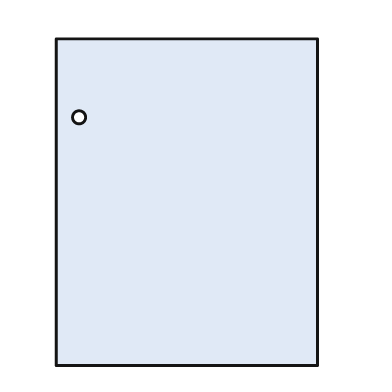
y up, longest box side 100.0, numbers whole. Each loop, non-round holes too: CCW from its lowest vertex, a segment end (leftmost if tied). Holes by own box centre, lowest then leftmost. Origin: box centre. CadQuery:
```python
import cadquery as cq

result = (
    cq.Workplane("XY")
    .moveTo(-40.0, -50.0)
    .lineTo(40.0, -50.0)
    .lineTo(40.0, 50.0)
    .lineTo(-40.0, 50.0)
    .close()
    .moveTo(-33.0, 26.0)
    .circle(2.0)
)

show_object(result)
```